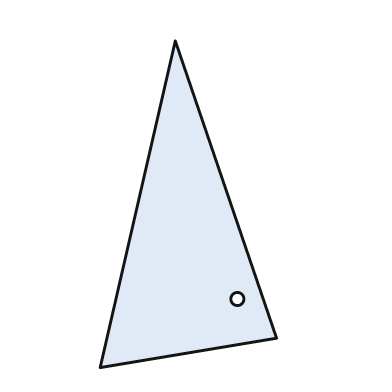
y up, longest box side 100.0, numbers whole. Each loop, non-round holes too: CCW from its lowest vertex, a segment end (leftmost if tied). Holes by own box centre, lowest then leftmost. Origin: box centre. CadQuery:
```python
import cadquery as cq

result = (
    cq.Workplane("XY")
    .moveTo(-27.0, -50.0)
    .lineTo(27.0, -41.0)
    .lineTo(-4.0, 50.0)
    .close()
    .moveTo(15.0, -29.0)
    .circle(2.0)
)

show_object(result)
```